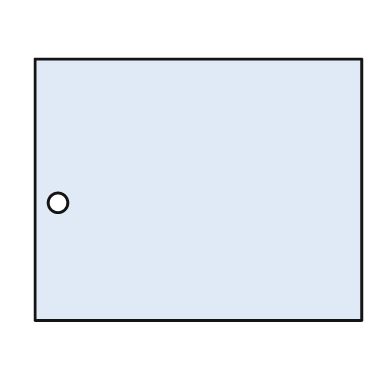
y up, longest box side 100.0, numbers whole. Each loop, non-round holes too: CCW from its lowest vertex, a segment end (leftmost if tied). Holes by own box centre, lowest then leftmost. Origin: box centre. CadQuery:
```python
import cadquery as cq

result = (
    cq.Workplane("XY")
    .moveTo(-50.0, -40.0)
    .lineTo(50.0, -40.0)
    .lineTo(50.0, 40.0)
    .lineTo(-50.0, 40.0)
    .close()
    .moveTo(-43.0, -4.0)
    .circle(3.0)
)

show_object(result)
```